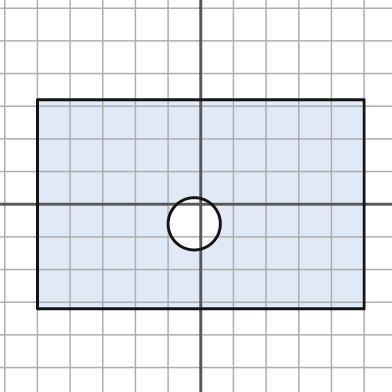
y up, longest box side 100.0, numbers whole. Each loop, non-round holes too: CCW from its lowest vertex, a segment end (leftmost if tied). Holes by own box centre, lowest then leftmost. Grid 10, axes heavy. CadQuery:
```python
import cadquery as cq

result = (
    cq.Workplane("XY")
    .moveTo(-50.0, -32.0)
    .lineTo(50.0, -32.0)
    .lineTo(50.0, 32.0)
    .lineTo(-50.0, 32.0)
    .close()
    .moveTo(-2.0, -6.0)
    .circle(8.0)
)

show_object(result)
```